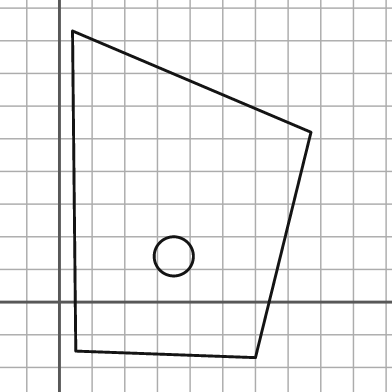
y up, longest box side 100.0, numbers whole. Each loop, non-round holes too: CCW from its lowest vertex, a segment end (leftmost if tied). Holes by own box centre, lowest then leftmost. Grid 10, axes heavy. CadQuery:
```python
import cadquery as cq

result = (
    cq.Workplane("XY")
    .moveTo(60.0, -17.0)
    .lineTo(77.0, 52.0)
    .lineTo(4.0, 83.0)
    .lineTo(5.0, -15.0)
    .close()
    .moveTo(35.0, 14.0)
    .circle(6.0)
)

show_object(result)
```